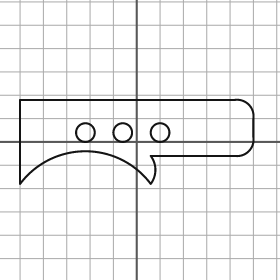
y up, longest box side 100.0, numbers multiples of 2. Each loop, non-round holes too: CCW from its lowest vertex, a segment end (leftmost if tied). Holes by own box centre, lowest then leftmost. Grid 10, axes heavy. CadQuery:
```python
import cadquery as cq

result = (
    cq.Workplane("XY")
    .moveTo(-50.0, -18.0)
    .threePointArc((-22.0, -4.0), (6.0, -18.0))
    .threePointArc((8.0, -12.0), (6.0, -6.0))
    .lineTo(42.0, -6.0)
    .threePointArc((48.0, -4.0), (50.0, 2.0))
    .lineTo(50.0, 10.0)
    .threePointArc((48.0, 16.0), (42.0, 18.0))
    .lineTo(-50.0, 18.0)
    .close()
    .moveTo(-22.0, 4.0)
    .circle(4.0)
    .moveTo(-6.0, 4.0)
    .circle(4.0)
    .moveTo(10.0, 4.0)
    .circle(4.0)
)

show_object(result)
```